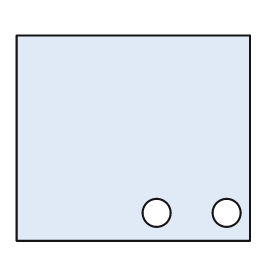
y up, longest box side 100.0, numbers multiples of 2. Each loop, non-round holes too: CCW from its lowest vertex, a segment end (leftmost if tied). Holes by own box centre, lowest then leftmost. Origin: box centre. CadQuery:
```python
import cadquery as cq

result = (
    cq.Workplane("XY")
    .moveTo(-50.0, -44.0)
    .lineTo(50.0, -44.0)
    .lineTo(50.0, 44.0)
    .lineTo(-50.0, 44.0)
    .close()
    .moveTo(10.0, -32.0)
    .circle(6.0)
    .moveTo(40.0, -32.0)
    .circle(6.0)
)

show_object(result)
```